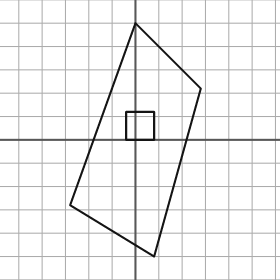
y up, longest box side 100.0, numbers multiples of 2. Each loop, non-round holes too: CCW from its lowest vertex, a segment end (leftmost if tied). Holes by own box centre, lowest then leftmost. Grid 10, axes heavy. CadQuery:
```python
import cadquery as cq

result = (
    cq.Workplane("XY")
    .moveTo(8.0, -50.0)
    .lineTo(28.0, 22.0)
    .lineTo(0.0, 50.0)
    .lineTo(-28.0, -28.0)
    .close()
    .moveTo(-4.0, 0.0)
    .lineTo(8.0, 0.0)
    .lineTo(8.0, 12.0)
    .lineTo(-4.0, 12.0)
    .close()
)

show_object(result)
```